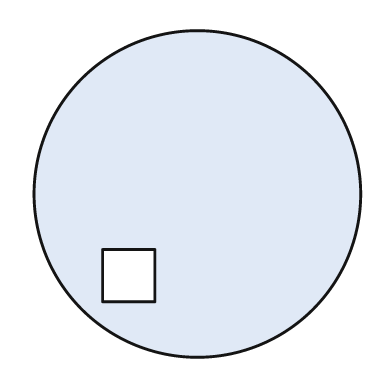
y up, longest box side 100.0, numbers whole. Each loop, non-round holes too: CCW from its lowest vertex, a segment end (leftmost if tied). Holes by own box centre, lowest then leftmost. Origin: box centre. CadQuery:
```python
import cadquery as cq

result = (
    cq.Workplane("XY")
    .moveTo(0.0, 0.0)
    .circle(50.0)
    .moveTo(-29.0, -33.0)
    .lineTo(-13.0, -33.0)
    .lineTo(-13.0, -17.0)
    .lineTo(-29.0, -17.0)
    .close()
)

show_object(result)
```